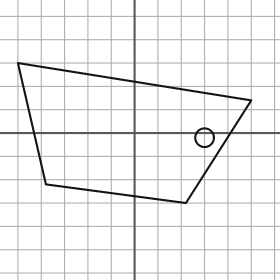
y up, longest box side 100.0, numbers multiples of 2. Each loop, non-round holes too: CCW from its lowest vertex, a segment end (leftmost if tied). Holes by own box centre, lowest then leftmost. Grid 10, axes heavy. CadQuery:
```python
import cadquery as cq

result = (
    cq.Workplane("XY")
    .moveTo(22.0, -30.0)
    .lineTo(50.0, 14.0)
    .lineTo(-50.0, 30.0)
    .lineTo(-38.0, -22.0)
    .close()
    .moveTo(30.0, -2.0)
    .circle(4.0)
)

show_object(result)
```